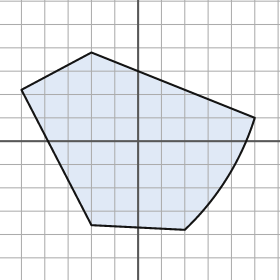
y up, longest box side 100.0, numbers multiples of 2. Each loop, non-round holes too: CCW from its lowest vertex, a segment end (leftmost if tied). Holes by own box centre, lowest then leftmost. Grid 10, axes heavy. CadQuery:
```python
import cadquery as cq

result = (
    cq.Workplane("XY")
    .moveTo(20.0, -38.0)
    .threePointArc((38.0, -16.0), (50.0, 10.0))
    .lineTo(-20.0, 38.0)
    .lineTo(-50.0, 22.0)
    .lineTo(-20.0, -36.0)
    .close()
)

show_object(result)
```